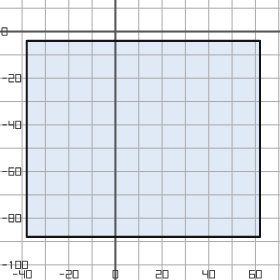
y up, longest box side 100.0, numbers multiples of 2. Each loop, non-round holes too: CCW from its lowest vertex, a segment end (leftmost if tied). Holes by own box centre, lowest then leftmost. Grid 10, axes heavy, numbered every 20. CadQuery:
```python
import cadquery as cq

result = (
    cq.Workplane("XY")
    .moveTo(-38.0, -88.0)
    .lineTo(62.0, -88.0)
    .lineTo(62.0, -4.0)
    .lineTo(-38.0, -4.0)
    .close()
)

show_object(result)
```